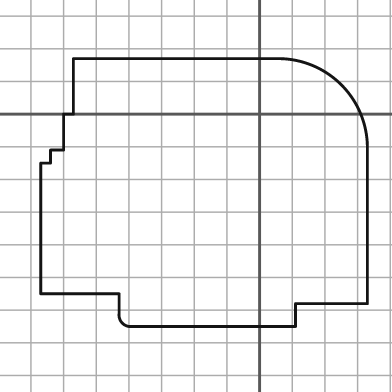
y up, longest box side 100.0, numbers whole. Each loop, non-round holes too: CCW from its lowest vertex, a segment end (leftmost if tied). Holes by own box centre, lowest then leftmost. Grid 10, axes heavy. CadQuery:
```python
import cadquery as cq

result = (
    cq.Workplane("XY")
    .moveTo(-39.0, -65.0)
    .lineTo(11.0, -65.0)
    .lineTo(11.0, -58.0)
    .lineTo(33.0, -58.0)
    .lineTo(33.0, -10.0)
    .threePointArc((25.0, 9.0), (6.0, 17.0))
    .lineTo(-57.0, 17.0)
    .lineTo(-57.0, 0.0)
    .lineTo(-60.0, 0.0)
    .lineTo(-60.0, -11.0)
    .lineTo(-64.0, -11.0)
    .lineTo(-64.0, -15.0)
    .lineTo(-67.0, -15.0)
    .lineTo(-67.0, -55.0)
    .lineTo(-43.0, -55.0)
    .lineTo(-43.0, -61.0)
    .threePointArc((-42.0, -64.0), (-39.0, -65.0))
    .close()
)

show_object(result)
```